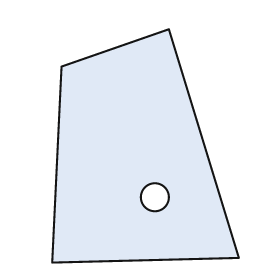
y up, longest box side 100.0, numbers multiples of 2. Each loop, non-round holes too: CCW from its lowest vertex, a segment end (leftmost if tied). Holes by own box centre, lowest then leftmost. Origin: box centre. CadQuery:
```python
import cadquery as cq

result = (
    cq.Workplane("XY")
    .moveTo(-40.0, -50.0)
    .lineTo(40.0, -48.0)
    .lineTo(10.0, 50.0)
    .lineTo(-36.0, 34.0)
    .close()
    .moveTo(4.0, -22.0)
    .circle(6.0)
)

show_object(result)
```